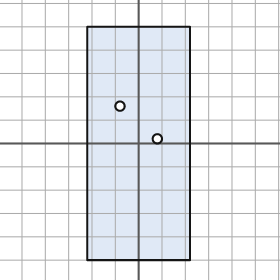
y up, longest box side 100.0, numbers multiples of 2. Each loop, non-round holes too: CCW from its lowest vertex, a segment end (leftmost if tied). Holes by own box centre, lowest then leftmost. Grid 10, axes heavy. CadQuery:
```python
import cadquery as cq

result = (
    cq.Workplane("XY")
    .moveTo(-22.0, -50.0)
    .lineTo(22.0, -50.0)
    .lineTo(22.0, 50.0)
    .lineTo(-22.0, 50.0)
    .close()
    .moveTo(8.0, 2.0)
    .circle(2.0)
    .moveTo(-8.0, 16.0)
    .circle(2.0)
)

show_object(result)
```